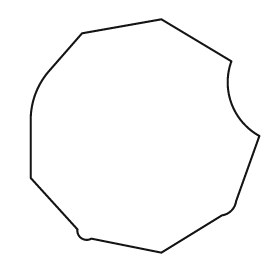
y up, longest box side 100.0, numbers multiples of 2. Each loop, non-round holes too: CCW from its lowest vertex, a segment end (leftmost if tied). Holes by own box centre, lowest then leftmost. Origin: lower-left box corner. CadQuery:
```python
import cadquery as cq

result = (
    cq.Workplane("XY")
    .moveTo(56.0, 0.0)
    .lineTo(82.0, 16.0)
    .threePointArc((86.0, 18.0), (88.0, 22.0))
    .lineTo(98.0, 50.0)
    .threePointArc((86.0, 64.0), (86.0, 82.0))
    .lineTo(56.0, 100.0)
    .lineTo(22.0, 94.0)
    .lineTo(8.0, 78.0)
    .threePointArc((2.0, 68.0), (0.0, 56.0))
    .lineTo(0.0, 32.0)
    .lineTo(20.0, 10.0)
    .threePointArc((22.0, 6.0), (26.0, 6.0))
    .close()
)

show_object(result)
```